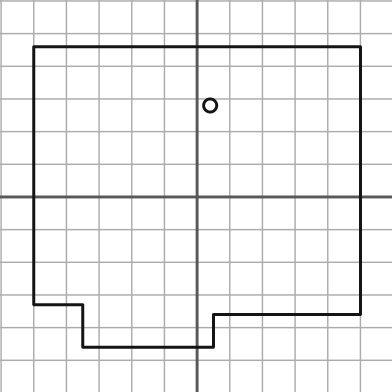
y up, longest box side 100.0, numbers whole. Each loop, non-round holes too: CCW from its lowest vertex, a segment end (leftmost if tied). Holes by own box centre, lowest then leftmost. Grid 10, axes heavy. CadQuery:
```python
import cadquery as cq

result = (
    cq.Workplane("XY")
    .moveTo(-35.0, -46.0)
    .lineTo(5.0, -46.0)
    .lineTo(5.0, -36.0)
    .lineTo(50.0, -36.0)
    .lineTo(50.0, 46.0)
    .lineTo(-50.0, 46.0)
    .lineTo(-50.0, -33.0)
    .lineTo(-35.0, -33.0)
    .close()
    .moveTo(4.0, 28.0)
    .circle(2.0)
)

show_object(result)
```